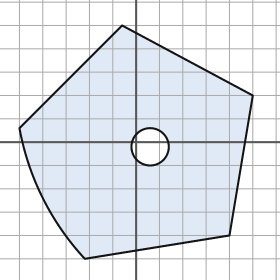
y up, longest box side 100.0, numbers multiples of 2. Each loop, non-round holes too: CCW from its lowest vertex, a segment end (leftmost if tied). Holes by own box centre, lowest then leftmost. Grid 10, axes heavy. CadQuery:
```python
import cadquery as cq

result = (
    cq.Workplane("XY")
    .moveTo(-22.0, -50.0)
    .lineTo(40.0, -40.0)
    .lineTo(50.0, 20.0)
    .lineTo(-6.0, 50.0)
    .lineTo(-50.0, 6.0)
    .threePointArc((-40.0, -24.0), (-22.0, -50.0))
    .close()
    .moveTo(6.0, -2.0)
    .circle(8.0)
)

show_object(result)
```